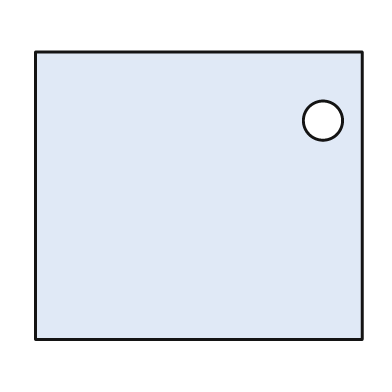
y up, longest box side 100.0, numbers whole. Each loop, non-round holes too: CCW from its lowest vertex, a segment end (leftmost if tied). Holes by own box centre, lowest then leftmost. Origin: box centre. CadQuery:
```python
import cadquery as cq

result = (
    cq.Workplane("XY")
    .moveTo(-50.0, -44.0)
    .lineTo(50.0, -44.0)
    .lineTo(50.0, 44.0)
    .lineTo(-50.0, 44.0)
    .close()
    .moveTo(38.0, 23.0)
    .circle(6.0)
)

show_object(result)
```